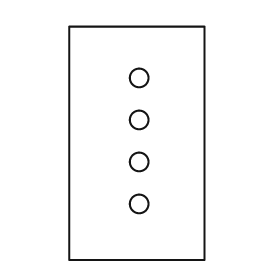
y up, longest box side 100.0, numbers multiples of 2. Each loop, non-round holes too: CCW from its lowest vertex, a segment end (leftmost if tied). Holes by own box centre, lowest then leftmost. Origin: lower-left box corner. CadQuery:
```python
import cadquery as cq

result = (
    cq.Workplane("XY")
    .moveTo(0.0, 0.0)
    .lineTo(58.0, 0.0)
    .lineTo(58.0, 100.0)
    .lineTo(0.0, 100.0)
    .close()
    .moveTo(30.0, 24.0)
    .circle(4.0)
    .moveTo(30.0, 42.0)
    .circle(4.0)
    .moveTo(30.0, 60.0)
    .circle(4.0)
    .moveTo(30.0, 78.0)
    .circle(4.0)
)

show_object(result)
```